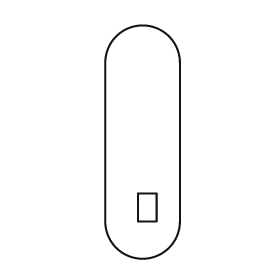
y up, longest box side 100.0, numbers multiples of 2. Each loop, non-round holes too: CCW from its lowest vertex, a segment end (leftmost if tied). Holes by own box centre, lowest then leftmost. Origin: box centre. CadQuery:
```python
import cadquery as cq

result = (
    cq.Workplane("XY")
    .moveTo(-16.0, -34.0)
    .threePointArc((0.0, -50.0), (16.0, -34.0))
    .lineTo(16.0, 34.0)
    .threePointArc((0.0, 50.0), (-16.0, 34.0))
    .close()
    .moveTo(-2.0, -34.0)
    .lineTo(6.0, -34.0)
    .lineTo(6.0, -22.0)
    .lineTo(-2.0, -22.0)
    .close()
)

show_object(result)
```